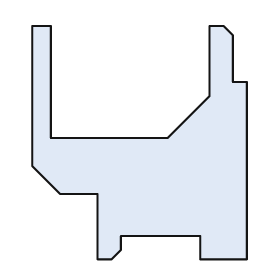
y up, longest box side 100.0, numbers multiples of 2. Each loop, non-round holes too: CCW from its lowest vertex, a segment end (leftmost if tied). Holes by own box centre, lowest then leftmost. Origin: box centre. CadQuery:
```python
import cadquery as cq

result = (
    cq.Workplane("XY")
    .moveTo(-18.0, -50.0)
    .lineTo(-12.0, -50.0)
    .lineTo(-8.0, -46.0)
    .lineTo(-8.0, -40.0)
    .lineTo(26.0, -40.0)
    .lineTo(26.0, -50.0)
    .lineTo(46.0, -50.0)
    .lineTo(46.0, 26.0)
    .lineTo(40.0, 26.0)
    .lineTo(40.0, 46.0)
    .lineTo(36.0, 50.0)
    .lineTo(30.0, 50.0)
    .lineTo(30.0, 20.0)
    .lineTo(12.0, 2.0)
    .lineTo(-38.0, 2.0)
    .lineTo(-38.0, 50.0)
    .lineTo(-46.0, 50.0)
    .lineTo(-46.0, -10.0)
    .lineTo(-34.0, -22.0)
    .lineTo(-18.0, -22.0)
    .close()
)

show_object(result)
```